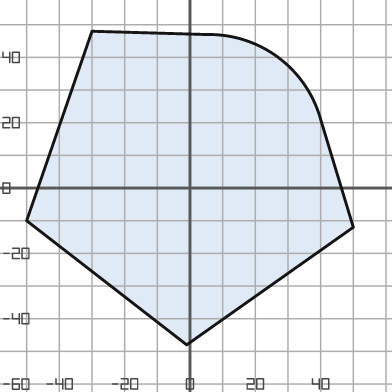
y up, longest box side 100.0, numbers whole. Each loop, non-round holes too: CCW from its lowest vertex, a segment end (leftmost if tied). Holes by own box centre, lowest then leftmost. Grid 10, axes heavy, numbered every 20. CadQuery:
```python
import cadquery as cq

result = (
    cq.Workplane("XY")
    .moveTo(-1.0, -48.0)
    .lineTo(50.0, -12.0)
    .lineTo(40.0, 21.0)
    .threePointArc((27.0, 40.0), (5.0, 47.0))
    .lineTo(-30.0, 48.0)
    .lineTo(-50.0, -10.0)
    .close()
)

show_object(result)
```